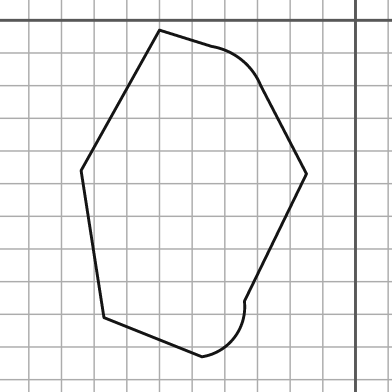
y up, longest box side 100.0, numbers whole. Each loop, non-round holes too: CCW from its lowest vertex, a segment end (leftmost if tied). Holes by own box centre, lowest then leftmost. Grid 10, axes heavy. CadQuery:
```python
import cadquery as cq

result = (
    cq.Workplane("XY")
    .moveTo(-47.0, -103.0)
    .threePointArc((-37.0, -97.0), (-34.0, -86.0))
    .lineTo(-15.0, -47.0)
    .lineTo(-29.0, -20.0)
    .threePointArc((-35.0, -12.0), (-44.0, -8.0))
    .lineTo(-60.0, -3.0)
    .lineTo(-84.0, -46.0)
    .lineTo(-77.0, -91.0)
    .close()
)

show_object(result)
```